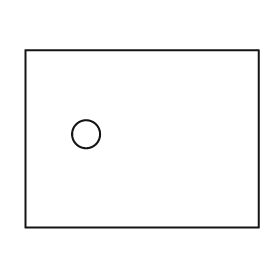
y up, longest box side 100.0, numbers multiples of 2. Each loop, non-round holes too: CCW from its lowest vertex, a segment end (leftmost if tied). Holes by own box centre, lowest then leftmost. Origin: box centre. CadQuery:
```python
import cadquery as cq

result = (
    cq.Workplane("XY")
    .moveTo(-50.0, -38.0)
    .lineTo(50.0, -38.0)
    .lineTo(50.0, 38.0)
    .lineTo(-50.0, 38.0)
    .close()
    .moveTo(-24.0, 2.0)
    .circle(6.0)
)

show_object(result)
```